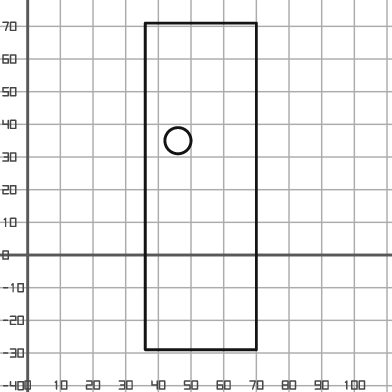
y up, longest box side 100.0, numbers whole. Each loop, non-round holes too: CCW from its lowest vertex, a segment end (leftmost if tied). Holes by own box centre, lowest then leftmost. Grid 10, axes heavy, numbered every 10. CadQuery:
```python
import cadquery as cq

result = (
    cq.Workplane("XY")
    .moveTo(36.0, -29.0)
    .lineTo(70.0, -29.0)
    .lineTo(70.0, 71.0)
    .lineTo(36.0, 71.0)
    .close()
    .moveTo(46.0, 35.0)
    .circle(4.0)
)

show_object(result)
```